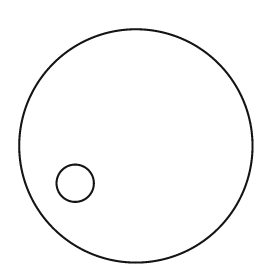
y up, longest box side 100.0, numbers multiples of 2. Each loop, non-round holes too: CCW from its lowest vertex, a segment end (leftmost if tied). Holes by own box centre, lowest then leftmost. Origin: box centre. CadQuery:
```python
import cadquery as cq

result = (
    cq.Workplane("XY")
    .moveTo(0.0, 0.0)
    .circle(50.0)
    .moveTo(-26.0, -16.0)
    .circle(8.0)
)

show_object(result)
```